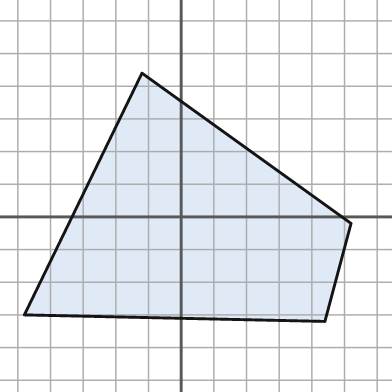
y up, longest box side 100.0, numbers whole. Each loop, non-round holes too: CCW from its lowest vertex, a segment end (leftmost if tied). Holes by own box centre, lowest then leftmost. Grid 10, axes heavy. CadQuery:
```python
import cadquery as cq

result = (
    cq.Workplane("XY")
    .moveTo(44.0, -32.0)
    .lineTo(52.0, -2.0)
    .lineTo(-12.0, 44.0)
    .lineTo(-48.0, -30.0)
    .close()
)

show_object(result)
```